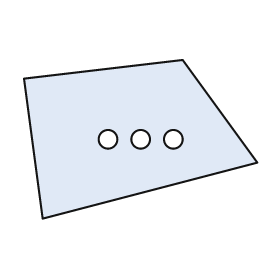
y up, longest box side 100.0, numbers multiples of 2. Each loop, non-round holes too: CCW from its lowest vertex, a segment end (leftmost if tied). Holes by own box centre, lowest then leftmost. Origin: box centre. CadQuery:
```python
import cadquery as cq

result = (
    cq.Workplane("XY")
    .moveTo(-42.0, -34.0)
    .lineTo(50.0, -10.0)
    .lineTo(18.0, 34.0)
    .lineTo(-50.0, 26.0)
    .close()
    .moveTo(-14.0, 0.0)
    .circle(4.0)
    .moveTo(0.0, 0.0)
    .circle(4.0)
    .moveTo(14.0, 0.0)
    .circle(4.0)
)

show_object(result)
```